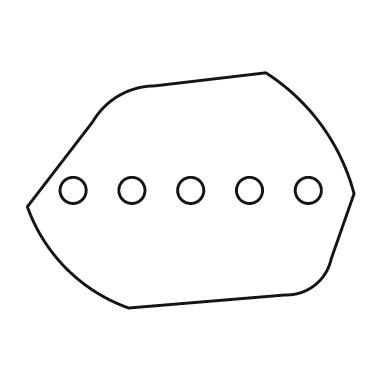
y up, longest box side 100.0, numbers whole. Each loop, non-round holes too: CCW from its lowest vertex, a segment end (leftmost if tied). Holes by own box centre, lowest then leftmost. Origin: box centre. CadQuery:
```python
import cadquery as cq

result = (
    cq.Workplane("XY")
    .moveTo(-19.0, -36.0)
    .lineTo(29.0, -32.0)
    .threePointArc((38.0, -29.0), (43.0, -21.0))
    .lineTo(50.0, -1.0)
    .threePointArc((40.0, 20.0), (23.0, 36.0))
    .lineTo(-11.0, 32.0)
    .threePointArc((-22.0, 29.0), (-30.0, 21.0))
    .lineTo(-50.0, -5.0)
    .threePointArc((-38.0, -24.0), (-19.0, -36.0))
    .close()
    .moveTo(-36.0, 0.0)
    .circle(4.0)
    .moveTo(-18.0, 0.0)
    .circle(4.0)
    .moveTo(0.0, 0.0)
    .circle(4.0)
    .moveTo(18.0, 0.0)
    .circle(4.0)
    .moveTo(36.0, 0.0)
    .circle(4.0)
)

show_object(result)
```